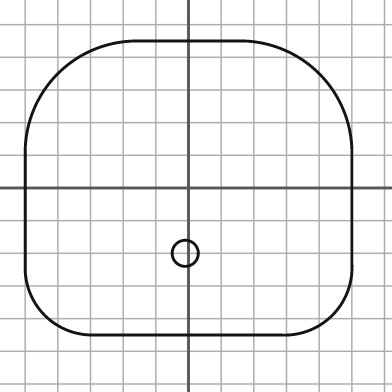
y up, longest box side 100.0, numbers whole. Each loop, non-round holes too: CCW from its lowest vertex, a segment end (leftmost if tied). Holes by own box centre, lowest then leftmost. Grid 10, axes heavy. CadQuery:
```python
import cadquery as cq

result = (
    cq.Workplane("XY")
    .moveTo(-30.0, -45.0)
    .lineTo(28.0, -45.0)
    .threePointArc((44.0, -39.0), (50.0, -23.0))
    .lineTo(50.0, 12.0)
    .threePointArc((40.0, 35.0), (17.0, 45.0))
    .lineTo(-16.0, 45.0)
    .threePointArc((-40.0, 35.0), (-50.0, 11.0))
    .lineTo(-50.0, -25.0)
    .threePointArc((-44.0, -39.0), (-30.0, -45.0))
    .close()
    .moveTo(-1.0, -20.0)
    .circle(4.0)
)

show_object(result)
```